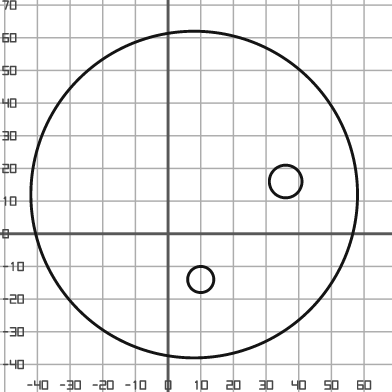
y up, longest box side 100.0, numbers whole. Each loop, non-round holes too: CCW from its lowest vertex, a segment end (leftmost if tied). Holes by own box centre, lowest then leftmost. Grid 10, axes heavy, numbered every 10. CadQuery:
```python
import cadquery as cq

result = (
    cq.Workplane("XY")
    .moveTo(8.0, 12.0)
    .circle(50.0)
    .moveTo(10.0, -14.0)
    .circle(4.0)
    .moveTo(36.0, 16.0)
    .circle(5.0)
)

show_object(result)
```